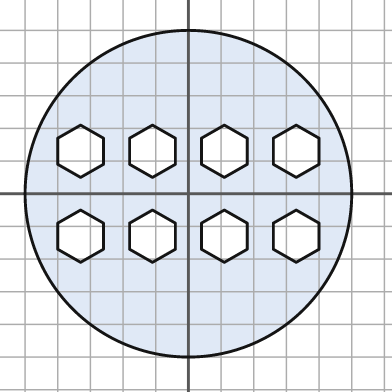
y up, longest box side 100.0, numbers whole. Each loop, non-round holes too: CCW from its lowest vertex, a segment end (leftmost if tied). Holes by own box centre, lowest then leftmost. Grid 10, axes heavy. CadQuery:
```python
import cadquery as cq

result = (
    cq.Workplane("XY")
    .moveTo(0.0, 0.0)
    .circle(50.0)
    .moveTo(-33.0, -21.0)
    .lineTo(-26.0, -17.0)
    .lineTo(-26.0, -9.0)
    .lineTo(-33.0, -5.0)
    .lineTo(-40.0, -9.0)
    .lineTo(-40.0, -17.0)
    .close()
    .moveTo(-11.0, -21.0)
    .lineTo(-4.0, -17.0)
    .lineTo(-4.0, -9.0)
    .lineTo(-11.0, -5.0)
    .lineTo(-18.0, -9.0)
    .lineTo(-18.0, -17.0)
    .close()
    .moveTo(11.0, -21.0)
    .lineTo(18.0, -17.0)
    .lineTo(18.0, -9.0)
    .lineTo(11.0, -5.0)
    .lineTo(4.0, -9.0)
    .lineTo(4.0, -17.0)
    .close()
    .moveTo(33.0, -21.0)
    .lineTo(40.0, -17.0)
    .lineTo(40.0, -9.0)
    .lineTo(33.0, -5.0)
    .lineTo(26.0, -9.0)
    .lineTo(26.0, -17.0)
    .close()
    .moveTo(-33.0, 5.0)
    .lineTo(-26.0, 9.0)
    .lineTo(-26.0, 17.0)
    .lineTo(-33.0, 21.0)
    .lineTo(-40.0, 17.0)
    .lineTo(-40.0, 9.0)
    .close()
    .moveTo(-11.0, 5.0)
    .lineTo(-4.0, 9.0)
    .lineTo(-4.0, 17.0)
    .lineTo(-11.0, 21.0)
    .lineTo(-18.0, 17.0)
    .lineTo(-18.0, 9.0)
    .close()
    .moveTo(11.0, 5.0)
    .lineTo(18.0, 9.0)
    .lineTo(18.0, 17.0)
    .lineTo(11.0, 21.0)
    .lineTo(4.0, 17.0)
    .lineTo(4.0, 9.0)
    .close()
    .moveTo(33.0, 5.0)
    .lineTo(40.0, 9.0)
    .lineTo(40.0, 17.0)
    .lineTo(33.0, 21.0)
    .lineTo(26.0, 17.0)
    .lineTo(26.0, 9.0)
    .close()
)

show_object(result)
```